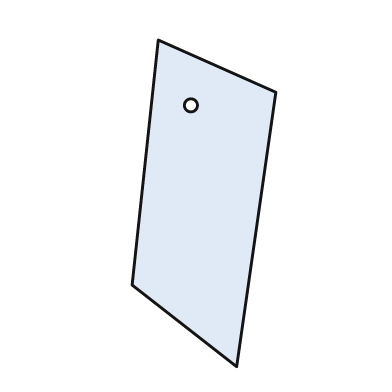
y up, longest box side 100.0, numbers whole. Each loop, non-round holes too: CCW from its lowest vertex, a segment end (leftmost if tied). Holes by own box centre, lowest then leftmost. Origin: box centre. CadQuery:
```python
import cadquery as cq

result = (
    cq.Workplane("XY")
    .moveTo(10.0, -50.0)
    .lineTo(22.0, 34.0)
    .lineTo(-14.0, 50.0)
    .lineTo(-22.0, -25.0)
    .close()
    .moveTo(-4.0, 30.0)
    .circle(2.0)
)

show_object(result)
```